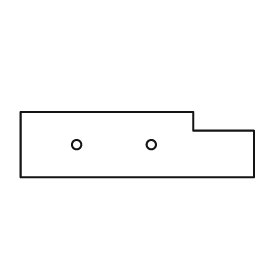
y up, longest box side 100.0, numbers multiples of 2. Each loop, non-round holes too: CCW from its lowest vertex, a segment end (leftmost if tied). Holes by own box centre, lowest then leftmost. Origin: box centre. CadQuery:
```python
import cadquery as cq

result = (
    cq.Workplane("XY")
    .moveTo(-50.0, -14.0)
    .lineTo(50.0, -14.0)
    .lineTo(50.0, 6.0)
    .lineTo(24.0, 6.0)
    .lineTo(24.0, 14.0)
    .lineTo(-50.0, 14.0)
    .close()
    .moveTo(-26.0, 0.0)
    .circle(2.0)
    .moveTo(6.0, 0.0)
    .circle(2.0)
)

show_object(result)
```